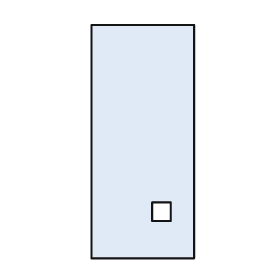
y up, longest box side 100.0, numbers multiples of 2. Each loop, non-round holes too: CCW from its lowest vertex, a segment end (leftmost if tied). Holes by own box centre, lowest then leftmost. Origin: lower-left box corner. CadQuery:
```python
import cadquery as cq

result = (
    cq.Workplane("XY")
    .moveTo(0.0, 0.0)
    .lineTo(44.0, 0.0)
    .lineTo(44.0, 100.0)
    .lineTo(0.0, 100.0)
    .close()
    .moveTo(26.0, 16.0)
    .lineTo(34.0, 16.0)
    .lineTo(34.0, 24.0)
    .lineTo(26.0, 24.0)
    .close()
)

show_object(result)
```